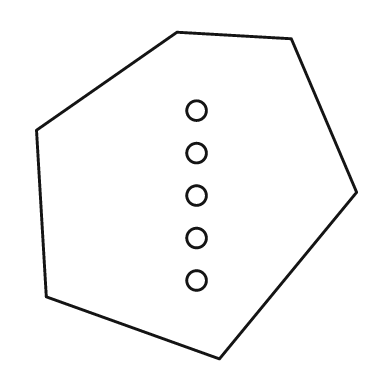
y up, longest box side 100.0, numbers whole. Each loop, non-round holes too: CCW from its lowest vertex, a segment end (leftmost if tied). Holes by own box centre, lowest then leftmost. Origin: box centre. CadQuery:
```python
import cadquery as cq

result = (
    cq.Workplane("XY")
    .moveTo(7.0, -50.0)
    .lineTo(49.0, 1.0)
    .lineTo(29.0, 48.0)
    .lineTo(-6.0, 50.0)
    .lineTo(-49.0, 20.0)
    .lineTo(-46.0, -31.0)
    .close()
    .moveTo(0.0, -26.0)
    .circle(3.0)
    .moveTo(0.0, -13.0)
    .circle(3.0)
    .moveTo(0.0, 0.0)
    .circle(3.0)
    .moveTo(0.0, 13.0)
    .circle(3.0)
    .moveTo(0.0, 26.0)
    .circle(3.0)
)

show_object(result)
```